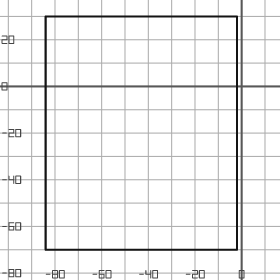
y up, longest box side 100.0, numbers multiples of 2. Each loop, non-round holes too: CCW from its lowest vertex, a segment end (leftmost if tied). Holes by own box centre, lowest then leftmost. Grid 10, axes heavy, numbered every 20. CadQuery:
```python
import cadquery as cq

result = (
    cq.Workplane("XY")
    .moveTo(-84.0, -70.0)
    .lineTo(-2.0, -70.0)
    .lineTo(-2.0, 30.0)
    .lineTo(-84.0, 30.0)
    .close()
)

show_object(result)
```